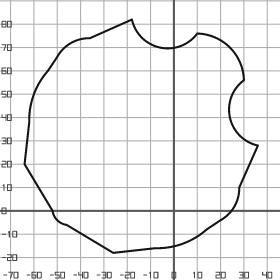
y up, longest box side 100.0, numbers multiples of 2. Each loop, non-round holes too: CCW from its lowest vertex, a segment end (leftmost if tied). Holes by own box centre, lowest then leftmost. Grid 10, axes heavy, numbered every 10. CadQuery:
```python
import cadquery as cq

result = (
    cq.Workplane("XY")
    .moveTo(-26.0, -18.0)
    .lineTo(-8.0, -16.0)
    .threePointArc((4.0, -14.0), (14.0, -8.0))
    .lineTo(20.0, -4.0)
    .threePointArc((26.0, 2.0), (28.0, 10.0))
    .lineTo(36.0, 28.0)
    .threePointArc((24.0, 40.0), (30.0, 56.0))
    .threePointArc((24.0, 70.0), (10.0, 76.0))
    .threePointArc((-6.0, 70.0), (-18.0, 82.0))
    .lineTo(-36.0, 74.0)
    .threePointArc((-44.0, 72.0), (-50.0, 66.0))
    .lineTo(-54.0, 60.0)
    .threePointArc((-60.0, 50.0), (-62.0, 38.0))
    .lineTo(-64.0, 20.0)
    .lineTo(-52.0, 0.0)
    .threePointArc((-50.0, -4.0), (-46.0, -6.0))
    .close()
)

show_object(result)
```